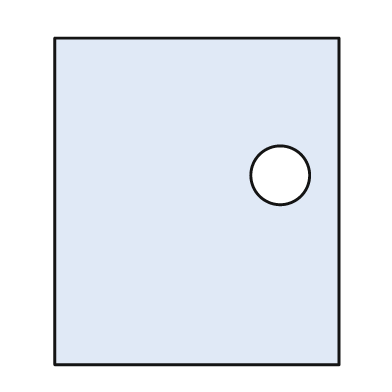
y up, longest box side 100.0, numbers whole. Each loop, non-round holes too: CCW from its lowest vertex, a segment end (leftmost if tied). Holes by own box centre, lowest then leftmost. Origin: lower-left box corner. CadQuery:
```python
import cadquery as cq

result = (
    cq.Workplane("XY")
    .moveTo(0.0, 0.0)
    .lineTo(87.0, 0.0)
    .lineTo(87.0, 100.0)
    .lineTo(0.0, 100.0)
    .close()
    .moveTo(69.0, 58.0)
    .circle(9.0)
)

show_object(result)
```